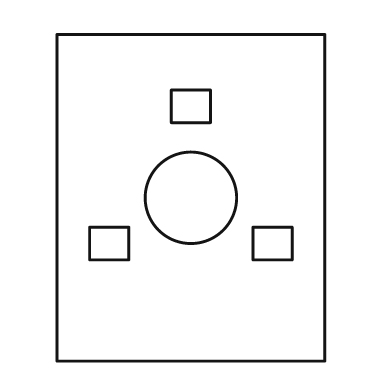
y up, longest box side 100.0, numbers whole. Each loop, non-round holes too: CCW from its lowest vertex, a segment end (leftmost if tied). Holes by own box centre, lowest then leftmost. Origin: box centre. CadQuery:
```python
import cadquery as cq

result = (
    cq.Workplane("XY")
    .moveTo(-41.0, -50.0)
    .lineTo(41.0, -50.0)
    .lineTo(41.0, 50.0)
    .lineTo(-41.0, 50.0)
    .close()
    .moveTo(-31.0, -19.0)
    .lineTo(-19.0, -19.0)
    .lineTo(-19.0, -9.0)
    .lineTo(-31.0, -9.0)
    .close()
    .moveTo(19.0, -19.0)
    .lineTo(31.0, -19.0)
    .lineTo(31.0, -9.0)
    .lineTo(19.0, -9.0)
    .close()
    .moveTo(0.0, 0.0)
    .circle(14.0)
    .moveTo(-6.0, 23.0)
    .lineTo(6.0, 23.0)
    .lineTo(6.0, 33.0)
    .lineTo(-6.0, 33.0)
    .close()
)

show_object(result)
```